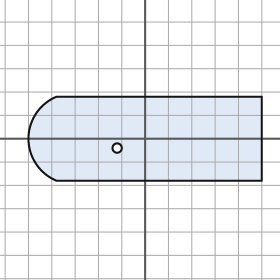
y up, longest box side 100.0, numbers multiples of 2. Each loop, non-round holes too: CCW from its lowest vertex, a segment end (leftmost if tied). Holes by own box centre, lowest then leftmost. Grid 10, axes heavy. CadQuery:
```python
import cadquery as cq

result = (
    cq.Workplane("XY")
    .moveTo(-38.0, -18.0)
    .lineTo(50.0, -18.0)
    .lineTo(50.0, 18.0)
    .lineTo(-38.0, 18.0)
    .threePointArc((-50.0, 0.0), (-38.0, -18.0))
    .close()
    .moveTo(-12.0, -4.0)
    .circle(2.0)
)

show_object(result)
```